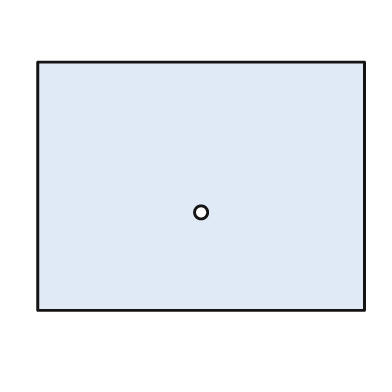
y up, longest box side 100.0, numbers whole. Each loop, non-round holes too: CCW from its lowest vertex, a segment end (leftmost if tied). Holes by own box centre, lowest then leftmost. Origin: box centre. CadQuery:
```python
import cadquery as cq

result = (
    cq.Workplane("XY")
    .moveTo(-50.0, -38.0)
    .lineTo(50.0, -38.0)
    .lineTo(50.0, 38.0)
    .lineTo(-50.0, 38.0)
    .close()
    .moveTo(0.0, -8.0)
    .circle(2.0)
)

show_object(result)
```